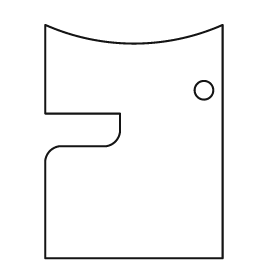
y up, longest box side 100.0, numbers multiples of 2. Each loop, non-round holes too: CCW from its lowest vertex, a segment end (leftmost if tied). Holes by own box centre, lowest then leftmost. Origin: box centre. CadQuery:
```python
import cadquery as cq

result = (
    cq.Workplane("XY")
    .moveTo(-38.0, -50.0)
    .lineTo(38.0, -50.0)
    .lineTo(38.0, 50.0)
    .threePointArc((0.0, 42.0), (-38.0, 50.0))
    .lineTo(-38.0, 12.0)
    .lineTo(-6.0, 12.0)
    .lineTo(-6.0, 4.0)
    .threePointArc((-8.0, 0.0), (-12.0, -2.0))
    .lineTo(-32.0, -2.0)
    .threePointArc((-36.0, -4.0), (-38.0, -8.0))
    .close()
    .moveTo(30.0, 22.0)
    .circle(4.0)
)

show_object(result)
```